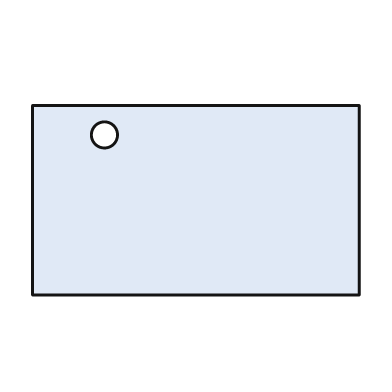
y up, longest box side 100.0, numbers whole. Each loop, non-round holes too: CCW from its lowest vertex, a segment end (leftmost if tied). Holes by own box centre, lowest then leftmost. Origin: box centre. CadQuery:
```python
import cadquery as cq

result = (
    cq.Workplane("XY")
    .moveTo(-50.0, -29.0)
    .lineTo(50.0, -29.0)
    .lineTo(50.0, 29.0)
    .lineTo(-50.0, 29.0)
    .close()
    .moveTo(-28.0, 20.0)
    .circle(4.0)
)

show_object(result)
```